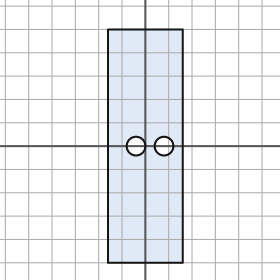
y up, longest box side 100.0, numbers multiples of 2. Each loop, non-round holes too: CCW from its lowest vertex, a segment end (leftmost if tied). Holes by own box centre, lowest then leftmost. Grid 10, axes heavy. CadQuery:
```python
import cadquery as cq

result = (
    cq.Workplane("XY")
    .moveTo(-16.0, -50.0)
    .lineTo(16.0, -50.0)
    .lineTo(16.0, 50.0)
    .lineTo(-16.0, 50.0)
    .close()
    .moveTo(-4.0, 0.0)
    .circle(4.0)
    .moveTo(8.0, 0.0)
    .circle(4.0)
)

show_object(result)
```